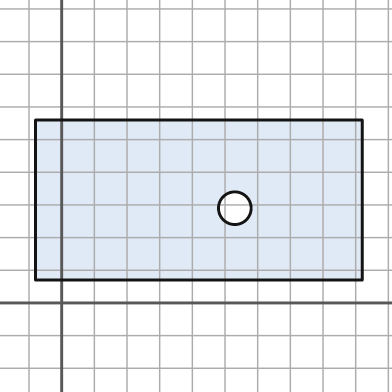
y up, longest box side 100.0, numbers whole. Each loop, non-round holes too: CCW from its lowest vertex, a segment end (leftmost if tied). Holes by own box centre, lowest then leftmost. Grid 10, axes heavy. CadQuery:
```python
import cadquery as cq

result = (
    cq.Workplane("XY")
    .moveTo(-8.0, 7.0)
    .lineTo(92.0, 7.0)
    .lineTo(92.0, 56.0)
    .lineTo(-8.0, 56.0)
    .close()
    .moveTo(53.0, 29.0)
    .circle(5.0)
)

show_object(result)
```